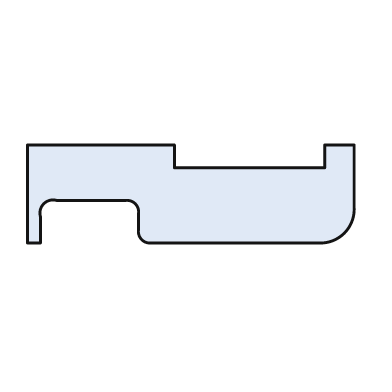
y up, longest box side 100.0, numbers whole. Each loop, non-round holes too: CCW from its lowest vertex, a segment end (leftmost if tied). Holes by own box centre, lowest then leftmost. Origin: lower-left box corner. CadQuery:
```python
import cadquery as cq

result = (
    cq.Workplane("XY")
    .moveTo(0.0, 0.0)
    .lineTo(4.0, 0.0)
    .lineTo(4.0, 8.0)
    .threePointArc((5.0, 12.0), (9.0, 13.0))
    .lineTo(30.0, 13.0)
    .threePointArc((33.0, 12.0), (34.0, 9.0))
    .lineTo(34.0, 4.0)
    .threePointArc((35.0, 1.0), (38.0, 0.0))
    .lineTo(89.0, 0.0)
    .threePointArc((97.0, 3.0), (100.0, 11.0))
    .lineTo(100.0, 30.0)
    .lineTo(91.0, 30.0)
    .lineTo(91.0, 23.0)
    .lineTo(45.0, 23.0)
    .lineTo(45.0, 30.0)
    .lineTo(0.0, 30.0)
    .close()
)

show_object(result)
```